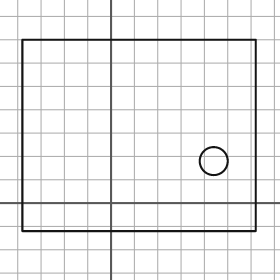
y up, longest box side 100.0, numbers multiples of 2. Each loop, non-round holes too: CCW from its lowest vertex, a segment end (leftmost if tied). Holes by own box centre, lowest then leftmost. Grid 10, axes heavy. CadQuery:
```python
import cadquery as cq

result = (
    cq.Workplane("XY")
    .moveTo(-38.0, -12.0)
    .lineTo(62.0, -12.0)
    .lineTo(62.0, 70.0)
    .lineTo(-38.0, 70.0)
    .close()
    .moveTo(44.0, 18.0)
    .circle(6.0)
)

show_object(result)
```